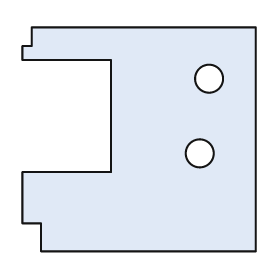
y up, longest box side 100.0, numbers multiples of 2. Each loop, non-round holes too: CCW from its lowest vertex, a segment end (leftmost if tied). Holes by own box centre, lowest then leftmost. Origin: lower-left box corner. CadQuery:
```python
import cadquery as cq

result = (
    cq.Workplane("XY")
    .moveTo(8.0, 0.0)
    .lineTo(100.0, 0.0)
    .lineTo(100.0, 96.0)
    .lineTo(4.0, 96.0)
    .lineTo(4.0, 88.0)
    .lineTo(0.0, 88.0)
    .lineTo(0.0, 82.0)
    .lineTo(38.0, 82.0)
    .lineTo(38.0, 34.0)
    .lineTo(0.0, 34.0)
    .lineTo(0.0, 12.0)
    .lineTo(8.0, 12.0)
    .close()
    .moveTo(76.0, 42.0)
    .circle(6.0)
    .moveTo(80.0, 74.0)
    .circle(6.0)
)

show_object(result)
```